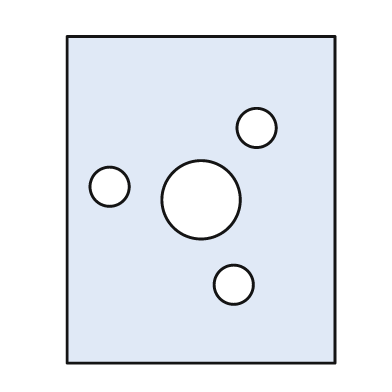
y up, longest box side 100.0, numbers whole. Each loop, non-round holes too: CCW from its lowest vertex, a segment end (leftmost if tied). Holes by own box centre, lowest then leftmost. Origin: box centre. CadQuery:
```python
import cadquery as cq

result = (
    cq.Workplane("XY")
    .moveTo(-41.0, -50.0)
    .lineTo(41.0, -50.0)
    .lineTo(41.0, 50.0)
    .lineTo(-41.0, 50.0)
    .close()
    .moveTo(10.0, -26.0)
    .circle(6.0)
    .moveTo(0.0, 0.0)
    .circle(12.0)
    .moveTo(-28.0, 4.0)
    .circle(6.0)
    .moveTo(17.0, 22.0)
    .circle(6.0)
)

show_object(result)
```